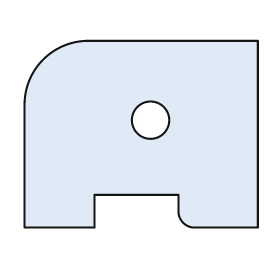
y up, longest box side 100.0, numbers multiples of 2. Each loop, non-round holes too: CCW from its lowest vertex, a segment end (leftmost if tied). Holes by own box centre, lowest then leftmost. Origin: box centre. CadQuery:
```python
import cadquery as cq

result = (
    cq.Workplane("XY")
    .moveTo(-50.0, -40.0)
    .lineTo(-20.0, -40.0)
    .lineTo(-20.0, -26.0)
    .lineTo(16.0, -26.0)
    .lineTo(16.0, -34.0)
    .threePointArc((18.0, -38.0), (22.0, -40.0))
    .lineTo(50.0, -40.0)
    .lineTo(50.0, 40.0)
    .lineTo(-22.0, 40.0)
    .threePointArc((-42.0, 32.0), (-50.0, 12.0))
    .close()
    .moveTo(4.0, 6.0)
    .circle(8.0)
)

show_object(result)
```